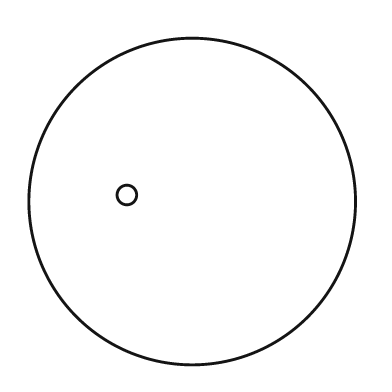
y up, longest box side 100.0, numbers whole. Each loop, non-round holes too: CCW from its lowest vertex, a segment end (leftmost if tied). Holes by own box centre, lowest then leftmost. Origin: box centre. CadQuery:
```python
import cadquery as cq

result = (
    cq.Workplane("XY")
    .moveTo(0.0, 0.0)
    .circle(50.0)
    .moveTo(-20.0, 2.0)
    .circle(3.0)
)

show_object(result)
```